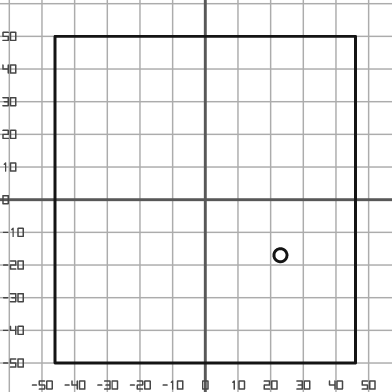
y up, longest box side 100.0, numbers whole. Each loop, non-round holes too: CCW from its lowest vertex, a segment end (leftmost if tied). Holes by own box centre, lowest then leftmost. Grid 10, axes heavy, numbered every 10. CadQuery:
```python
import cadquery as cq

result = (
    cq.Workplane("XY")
    .moveTo(-46.0, -50.0)
    .lineTo(46.0, -50.0)
    .lineTo(46.0, 50.0)
    .lineTo(-46.0, 50.0)
    .close()
    .moveTo(23.0, -17.0)
    .circle(2.0)
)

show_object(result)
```